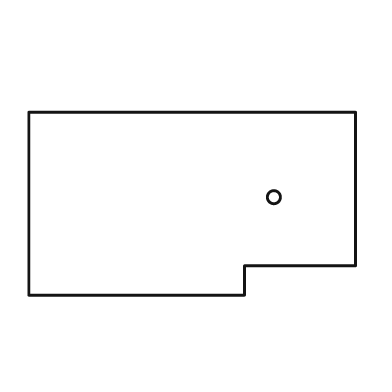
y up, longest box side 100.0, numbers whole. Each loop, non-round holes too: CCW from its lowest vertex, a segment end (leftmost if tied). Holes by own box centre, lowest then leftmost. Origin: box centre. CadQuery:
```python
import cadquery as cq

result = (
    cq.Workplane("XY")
    .moveTo(-50.0, -28.0)
    .lineTo(16.0, -28.0)
    .lineTo(16.0, -19.0)
    .lineTo(50.0, -19.0)
    .lineTo(50.0, 28.0)
    .lineTo(-50.0, 28.0)
    .close()
    .moveTo(25.0, 2.0)
    .circle(2.0)
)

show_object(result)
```